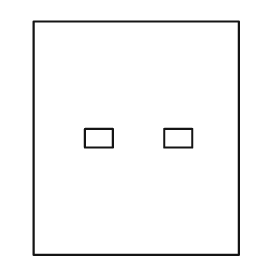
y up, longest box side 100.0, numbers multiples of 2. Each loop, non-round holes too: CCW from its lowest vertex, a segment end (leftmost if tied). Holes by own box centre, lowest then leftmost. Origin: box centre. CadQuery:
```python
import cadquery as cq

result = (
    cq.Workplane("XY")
    .moveTo(-44.0, -50.0)
    .lineTo(44.0, -50.0)
    .lineTo(44.0, 50.0)
    .lineTo(-44.0, 50.0)
    .close()
    .moveTo(-22.0, -4.0)
    .lineTo(-10.0, -4.0)
    .lineTo(-10.0, 4.0)
    .lineTo(-22.0, 4.0)
    .close()
    .moveTo(12.0, -4.0)
    .lineTo(24.0, -4.0)
    .lineTo(24.0, 4.0)
    .lineTo(12.0, 4.0)
    .close()
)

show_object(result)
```